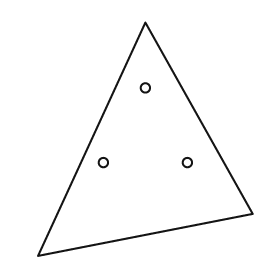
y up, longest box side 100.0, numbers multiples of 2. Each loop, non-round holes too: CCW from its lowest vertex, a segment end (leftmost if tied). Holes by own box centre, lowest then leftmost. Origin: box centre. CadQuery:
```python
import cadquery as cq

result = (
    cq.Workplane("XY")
    .moveTo(-46.0, -50.0)
    .lineTo(46.0, -32.0)
    .lineTo(0.0, 50.0)
    .close()
    .moveTo(-18.0, -10.0)
    .circle(2.0)
    .moveTo(18.0, -10.0)
    .circle(2.0)
    .moveTo(0.0, 22.0)
    .circle(2.0)
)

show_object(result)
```